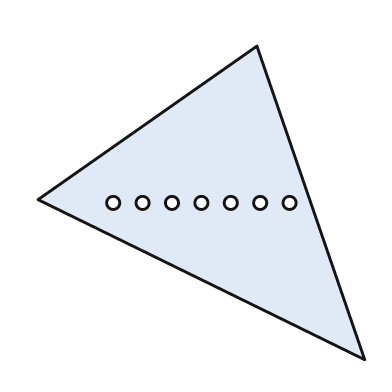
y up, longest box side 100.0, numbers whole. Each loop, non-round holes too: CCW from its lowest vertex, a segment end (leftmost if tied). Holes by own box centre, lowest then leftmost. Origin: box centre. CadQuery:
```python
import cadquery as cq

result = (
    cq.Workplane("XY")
    .moveTo(50.0, -48.0)
    .lineTo(17.0, 48.0)
    .lineTo(-50.0, 1.0)
    .close()
    .moveTo(-27.0, 0.0)
    .circle(2.0)
    .moveTo(-18.0, 0.0)
    .circle(2.0)
    .moveTo(-9.0, 0.0)
    .circle(2.0)
    .moveTo(0.0, 0.0)
    .circle(2.0)
    .moveTo(9.0, 0.0)
    .circle(2.0)
    .moveTo(18.0, 0.0)
    .circle(2.0)
    .moveTo(27.0, 0.0)
    .circle(2.0)
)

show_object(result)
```